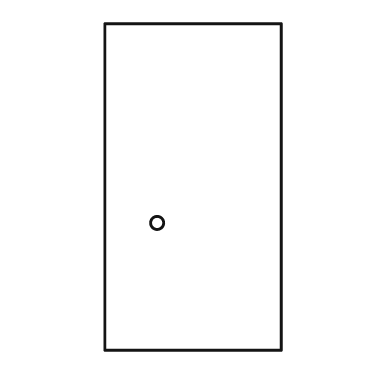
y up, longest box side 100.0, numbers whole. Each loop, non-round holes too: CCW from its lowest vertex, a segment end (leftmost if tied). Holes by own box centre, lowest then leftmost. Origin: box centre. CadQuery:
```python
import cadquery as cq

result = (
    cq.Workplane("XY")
    .moveTo(-27.0, -50.0)
    .lineTo(27.0, -50.0)
    .lineTo(27.0, 50.0)
    .lineTo(-27.0, 50.0)
    .close()
    .moveTo(-11.0, -11.0)
    .circle(2.0)
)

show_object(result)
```